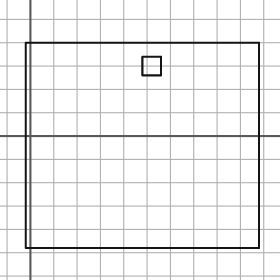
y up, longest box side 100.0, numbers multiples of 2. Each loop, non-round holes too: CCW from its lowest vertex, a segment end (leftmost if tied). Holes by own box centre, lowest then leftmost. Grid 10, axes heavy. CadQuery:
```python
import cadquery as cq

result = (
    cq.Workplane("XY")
    .moveTo(-2.0, -48.0)
    .lineTo(98.0, -48.0)
    .lineTo(98.0, 40.0)
    .lineTo(-2.0, 40.0)
    .close()
    .moveTo(48.0, 26.0)
    .lineTo(56.0, 26.0)
    .lineTo(56.0, 34.0)
    .lineTo(48.0, 34.0)
    .close()
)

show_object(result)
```